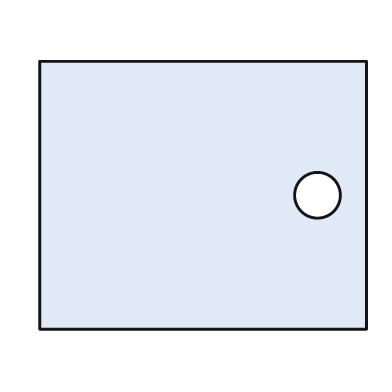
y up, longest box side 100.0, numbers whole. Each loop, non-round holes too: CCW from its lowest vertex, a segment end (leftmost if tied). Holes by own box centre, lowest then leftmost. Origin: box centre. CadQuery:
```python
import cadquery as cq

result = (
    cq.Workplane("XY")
    .moveTo(-50.0, -41.0)
    .lineTo(50.0, -41.0)
    .lineTo(50.0, 41.0)
    .lineTo(-50.0, 41.0)
    .close()
    .moveTo(35.0, 0.0)
    .circle(7.0)
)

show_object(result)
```